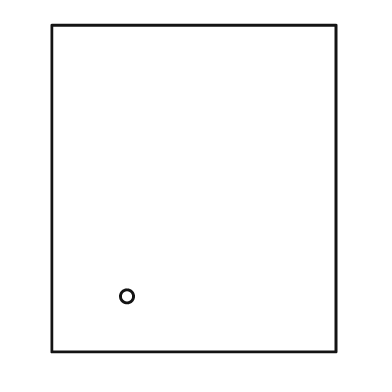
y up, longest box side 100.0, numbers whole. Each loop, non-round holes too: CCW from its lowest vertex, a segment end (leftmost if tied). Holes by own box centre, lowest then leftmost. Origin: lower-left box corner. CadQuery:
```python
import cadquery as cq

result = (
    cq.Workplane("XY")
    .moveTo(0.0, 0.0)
    .lineTo(87.0, 0.0)
    .lineTo(87.0, 100.0)
    .lineTo(0.0, 100.0)
    .close()
    .moveTo(23.0, 17.0)
    .circle(2.0)
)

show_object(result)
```